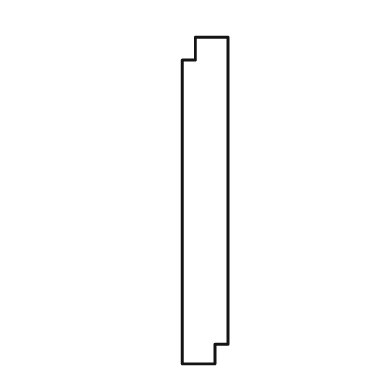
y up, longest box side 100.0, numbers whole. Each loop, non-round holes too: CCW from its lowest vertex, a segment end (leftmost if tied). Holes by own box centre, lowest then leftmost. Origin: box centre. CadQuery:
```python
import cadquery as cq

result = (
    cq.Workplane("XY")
    .moveTo(-7.0, -50.0)
    .lineTo(3.0, -50.0)
    .lineTo(3.0, -44.0)
    .lineTo(7.0, -44.0)
    .lineTo(7.0, 50.0)
    .lineTo(-3.0, 50.0)
    .lineTo(-3.0, 43.0)
    .lineTo(-7.0, 43.0)
    .close()
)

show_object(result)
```